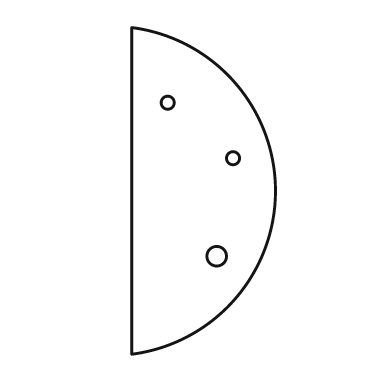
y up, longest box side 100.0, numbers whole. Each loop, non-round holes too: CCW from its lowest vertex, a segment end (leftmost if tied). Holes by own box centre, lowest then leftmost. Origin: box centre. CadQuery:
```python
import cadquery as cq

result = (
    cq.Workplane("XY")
    .moveTo(-22.0, -50.0)
    .threePointArc((22.0, 0.0), (-22.0, 50.0))
    .close()
    .moveTo(4.0, -20.0)
    .circle(3.0)
    .moveTo(9.0, 10.0)
    .circle(2.0)
    .moveTo(-11.0, 27.0)
    .circle(2.0)
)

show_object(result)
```